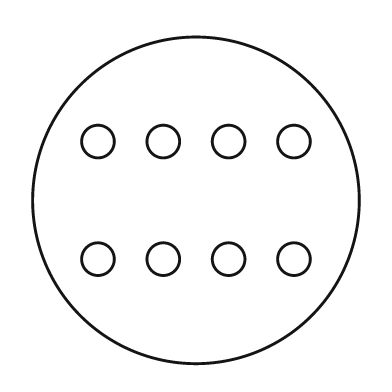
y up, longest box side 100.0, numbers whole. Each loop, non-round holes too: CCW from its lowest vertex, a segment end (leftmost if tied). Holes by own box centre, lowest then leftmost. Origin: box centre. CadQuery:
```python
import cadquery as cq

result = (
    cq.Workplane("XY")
    .moveTo(0.0, 0.0)
    .circle(50.0)
    .moveTo(-30.0, -18.0)
    .circle(5.0)
    .moveTo(-10.0, -18.0)
    .circle(5.0)
    .moveTo(10.0, -18.0)
    .circle(5.0)
    .moveTo(30.0, -18.0)
    .circle(5.0)
    .moveTo(-30.0, 18.0)
    .circle(5.0)
    .moveTo(-10.0, 18.0)
    .circle(5.0)
    .moveTo(10.0, 18.0)
    .circle(5.0)
    .moveTo(30.0, 18.0)
    .circle(5.0)
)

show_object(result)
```